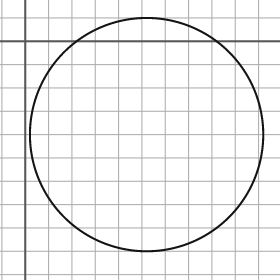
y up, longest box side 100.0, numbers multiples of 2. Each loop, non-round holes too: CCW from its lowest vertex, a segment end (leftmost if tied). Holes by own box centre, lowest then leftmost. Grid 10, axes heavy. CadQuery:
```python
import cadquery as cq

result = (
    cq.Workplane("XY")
    .moveTo(52.0, -40.0)
    .circle(50.0)
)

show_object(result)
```